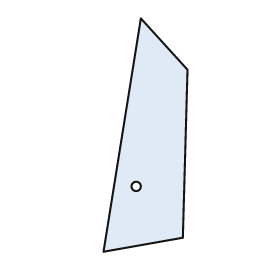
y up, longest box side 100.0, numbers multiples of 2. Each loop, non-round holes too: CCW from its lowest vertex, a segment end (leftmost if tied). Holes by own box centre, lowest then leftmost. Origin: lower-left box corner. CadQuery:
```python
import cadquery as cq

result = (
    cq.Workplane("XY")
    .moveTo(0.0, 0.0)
    .lineTo(34.0, 6.0)
    .lineTo(36.0, 78.0)
    .lineTo(16.0, 100.0)
    .close()
    .moveTo(14.0, 28.0)
    .circle(2.0)
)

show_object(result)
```